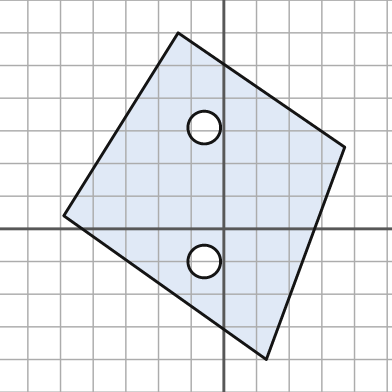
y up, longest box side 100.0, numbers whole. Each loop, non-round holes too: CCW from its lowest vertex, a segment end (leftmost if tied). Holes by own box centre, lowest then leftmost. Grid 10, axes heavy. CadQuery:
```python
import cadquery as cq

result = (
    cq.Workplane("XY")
    .moveTo(13.0, -40.0)
    .lineTo(37.0, 25.0)
    .lineTo(-14.0, 60.0)
    .lineTo(-49.0, 4.0)
    .close()
    .moveTo(-6.0, -10.0)
    .circle(5.0)
    .moveTo(-6.0, 31.0)
    .circle(5.0)
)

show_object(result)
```